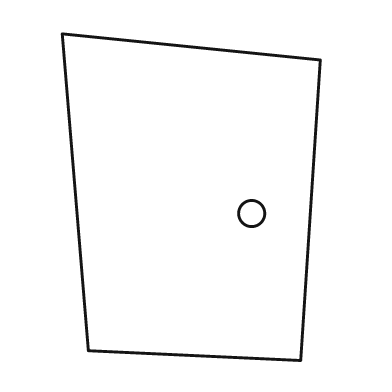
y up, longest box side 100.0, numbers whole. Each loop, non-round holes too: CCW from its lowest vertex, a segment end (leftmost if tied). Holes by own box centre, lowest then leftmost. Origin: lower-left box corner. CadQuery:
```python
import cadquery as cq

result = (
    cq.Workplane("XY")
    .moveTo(73.0, 0.0)
    .lineTo(79.0, 92.0)
    .lineTo(0.0, 100.0)
    .lineTo(8.0, 3.0)
    .close()
    .moveTo(58.0, 45.0)
    .circle(4.0)
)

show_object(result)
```